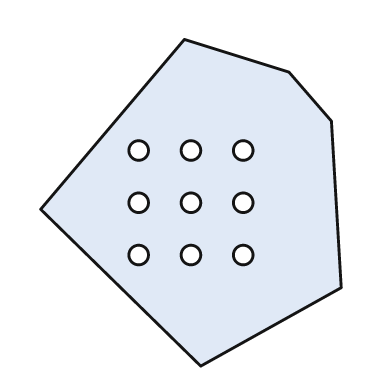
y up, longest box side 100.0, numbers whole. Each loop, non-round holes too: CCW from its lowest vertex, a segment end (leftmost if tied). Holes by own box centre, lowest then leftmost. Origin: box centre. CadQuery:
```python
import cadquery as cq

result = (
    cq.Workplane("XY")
    .moveTo(3.0, -50.0)
    .lineTo(46.0, -26.0)
    .lineTo(43.0, 25.0)
    .lineTo(30.0, 40.0)
    .lineTo(-2.0, 50.0)
    .lineTo(-46.0, -2.0)
    .close()
    .moveTo(-16.0, -16.0)
    .circle(3.0)
    .moveTo(0.0, -16.0)
    .circle(3.0)
    .moveTo(16.0, -16.0)
    .circle(3.0)
    .moveTo(-16.0, 0.0)
    .circle(3.0)
    .moveTo(0.0, 0.0)
    .circle(3.0)
    .moveTo(16.0, 0.0)
    .circle(3.0)
    .moveTo(-16.0, 16.0)
    .circle(3.0)
    .moveTo(0.0, 16.0)
    .circle(3.0)
    .moveTo(16.0, 16.0)
    .circle(3.0)
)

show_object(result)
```